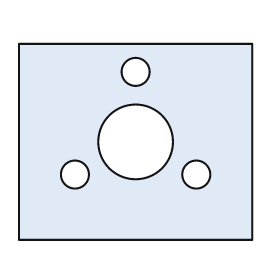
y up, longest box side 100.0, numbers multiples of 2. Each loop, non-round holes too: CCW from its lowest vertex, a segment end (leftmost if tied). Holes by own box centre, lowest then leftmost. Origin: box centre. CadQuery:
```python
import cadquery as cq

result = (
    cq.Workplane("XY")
    .moveTo(-50.0, -42.0)
    .lineTo(50.0, -42.0)
    .lineTo(50.0, 42.0)
    .lineTo(-50.0, 42.0)
    .close()
    .moveTo(-26.0, -14.0)
    .circle(6.0)
    .moveTo(26.0, -14.0)
    .circle(6.0)
    .moveTo(0.0, 0.0)
    .circle(16.0)
    .moveTo(0.0, 30.0)
    .circle(6.0)
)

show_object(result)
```